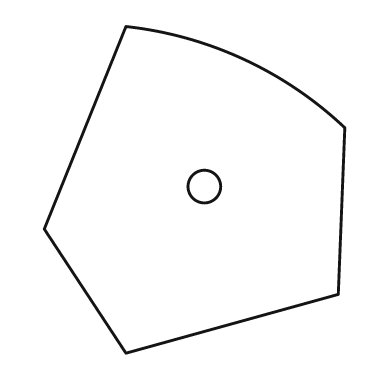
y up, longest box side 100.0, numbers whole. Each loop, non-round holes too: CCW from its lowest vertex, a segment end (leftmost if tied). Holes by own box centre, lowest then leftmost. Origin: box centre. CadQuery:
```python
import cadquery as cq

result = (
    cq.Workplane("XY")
    .moveTo(-21.0, -50.0)
    .lineTo(44.0, -32.0)
    .lineTo(46.0, 19.0)
    .threePointArc((15.0, 40.0), (-21.0, 50.0))
    .lineTo(-46.0, -12.0)
    .close()
    .moveTo(3.0, 1.0)
    .circle(5.0)
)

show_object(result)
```